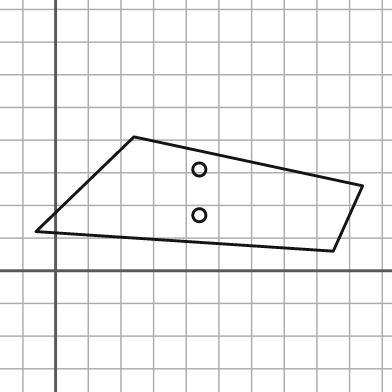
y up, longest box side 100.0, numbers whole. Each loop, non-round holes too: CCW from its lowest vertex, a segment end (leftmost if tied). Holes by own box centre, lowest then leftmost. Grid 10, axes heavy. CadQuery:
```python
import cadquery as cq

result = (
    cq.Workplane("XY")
    .moveTo(85.0, 6.0)
    .lineTo(94.0, 26.0)
    .lineTo(24.0, 41.0)
    .lineTo(-6.0, 12.0)
    .close()
    .moveTo(44.0, 17.0)
    .circle(2.0)
    .moveTo(44.0, 31.0)
    .circle(2.0)
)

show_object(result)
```